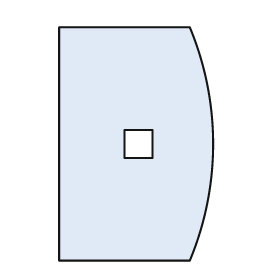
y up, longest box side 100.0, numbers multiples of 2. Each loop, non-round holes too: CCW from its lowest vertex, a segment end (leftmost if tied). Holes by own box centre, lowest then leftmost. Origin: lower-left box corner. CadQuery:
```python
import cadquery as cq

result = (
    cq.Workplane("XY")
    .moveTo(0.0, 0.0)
    .lineTo(56.0, 0.0)
    .threePointArc((66.0, 50.0), (56.0, 100.0))
    .lineTo(0.0, 100.0)
    .close()
    .moveTo(28.0, 44.0)
    .lineTo(40.0, 44.0)
    .lineTo(40.0, 56.0)
    .lineTo(28.0, 56.0)
    .close()
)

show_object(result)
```